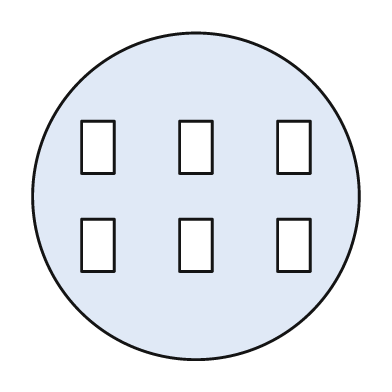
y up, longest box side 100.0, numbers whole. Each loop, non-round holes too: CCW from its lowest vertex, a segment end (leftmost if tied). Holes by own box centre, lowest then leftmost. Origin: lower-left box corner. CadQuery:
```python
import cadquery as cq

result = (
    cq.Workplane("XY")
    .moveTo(50.0, 50.0)
    .circle(50.0)
    .moveTo(15.0, 27.0)
    .lineTo(25.0, 27.0)
    .lineTo(25.0, 43.0)
    .lineTo(15.0, 43.0)
    .close()
    .moveTo(45.0, 27.0)
    .lineTo(55.0, 27.0)
    .lineTo(55.0, 43.0)
    .lineTo(45.0, 43.0)
    .close()
    .moveTo(75.0, 27.0)
    .lineTo(85.0, 27.0)
    .lineTo(85.0, 43.0)
    .lineTo(75.0, 43.0)
    .close()
    .moveTo(15.0, 57.0)
    .lineTo(25.0, 57.0)
    .lineTo(25.0, 73.0)
    .lineTo(15.0, 73.0)
    .close()
    .moveTo(45.0, 57.0)
    .lineTo(55.0, 57.0)
    .lineTo(55.0, 73.0)
    .lineTo(45.0, 73.0)
    .close()
    .moveTo(75.0, 57.0)
    .lineTo(85.0, 57.0)
    .lineTo(85.0, 73.0)
    .lineTo(75.0, 73.0)
    .close()
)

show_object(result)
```